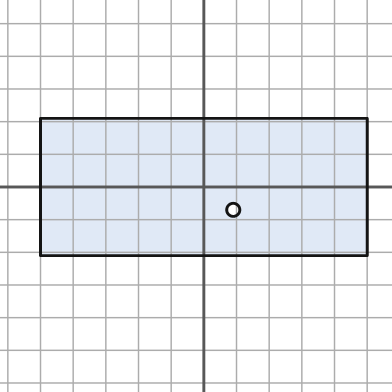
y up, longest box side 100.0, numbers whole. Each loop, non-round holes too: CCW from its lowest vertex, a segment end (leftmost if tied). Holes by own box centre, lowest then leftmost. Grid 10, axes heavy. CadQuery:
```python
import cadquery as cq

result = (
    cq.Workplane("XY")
    .moveTo(-50.0, -21.0)
    .lineTo(50.0, -21.0)
    .lineTo(50.0, 21.0)
    .lineTo(-50.0, 21.0)
    .close()
    .moveTo(9.0, -7.0)
    .circle(2.0)
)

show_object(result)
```